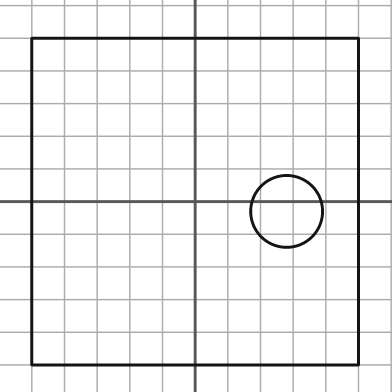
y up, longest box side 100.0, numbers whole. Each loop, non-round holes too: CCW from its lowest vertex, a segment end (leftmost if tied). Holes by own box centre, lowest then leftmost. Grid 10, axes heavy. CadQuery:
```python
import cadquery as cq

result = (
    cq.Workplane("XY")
    .moveTo(-50.0, -50.0)
    .lineTo(50.0, -50.0)
    .lineTo(50.0, 50.0)
    .lineTo(-50.0, 50.0)
    .close()
    .moveTo(28.0, -3.0)
    .circle(11.0)
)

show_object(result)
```